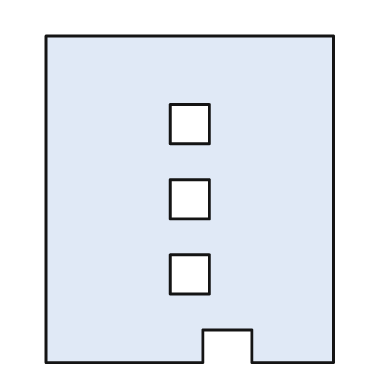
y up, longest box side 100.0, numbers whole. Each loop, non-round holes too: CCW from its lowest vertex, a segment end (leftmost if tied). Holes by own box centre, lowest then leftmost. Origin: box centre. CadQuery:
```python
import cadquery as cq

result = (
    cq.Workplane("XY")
    .moveTo(-44.0, -50.0)
    .lineTo(4.0, -50.0)
    .lineTo(4.0, -40.0)
    .lineTo(19.0, -40.0)
    .lineTo(19.0, -50.0)
    .lineTo(44.0, -50.0)
    .lineTo(44.0, 50.0)
    .lineTo(-44.0, 50.0)
    .close()
    .moveTo(-6.0, -29.0)
    .lineTo(6.0, -29.0)
    .lineTo(6.0, -17.0)
    .lineTo(-6.0, -17.0)
    .close()
    .moveTo(-6.0, -6.0)
    .lineTo(6.0, -6.0)
    .lineTo(6.0, 6.0)
    .lineTo(-6.0, 6.0)
    .close()
    .moveTo(-6.0, 17.0)
    .lineTo(6.0, 17.0)
    .lineTo(6.0, 29.0)
    .lineTo(-6.0, 29.0)
    .close()
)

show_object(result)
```